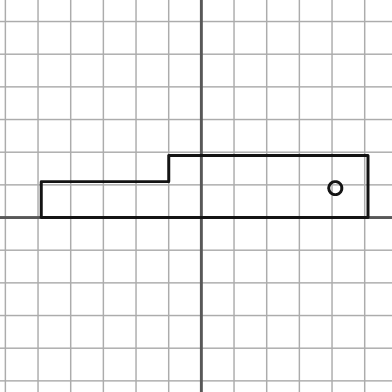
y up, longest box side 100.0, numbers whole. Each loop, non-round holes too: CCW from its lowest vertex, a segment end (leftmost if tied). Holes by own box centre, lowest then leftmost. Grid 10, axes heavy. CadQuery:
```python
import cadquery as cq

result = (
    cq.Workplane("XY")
    .moveTo(-49.0, 0.0)
    .lineTo(51.0, 0.0)
    .lineTo(51.0, 19.0)
    .lineTo(-10.0, 19.0)
    .lineTo(-10.0, 11.0)
    .lineTo(-49.0, 11.0)
    .close()
    .moveTo(41.0, 9.0)
    .circle(2.0)
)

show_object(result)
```